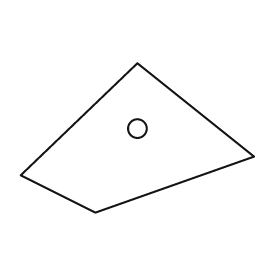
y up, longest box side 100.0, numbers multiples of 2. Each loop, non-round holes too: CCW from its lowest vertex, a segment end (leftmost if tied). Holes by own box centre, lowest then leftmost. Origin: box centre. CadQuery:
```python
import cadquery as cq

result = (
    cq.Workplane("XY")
    .moveTo(-18.0, -32.0)
    .lineTo(50.0, -8.0)
    .lineTo(0.0, 32.0)
    .lineTo(-50.0, -16.0)
    .close()
    .moveTo(0.0, 4.0)
    .circle(4.0)
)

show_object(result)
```